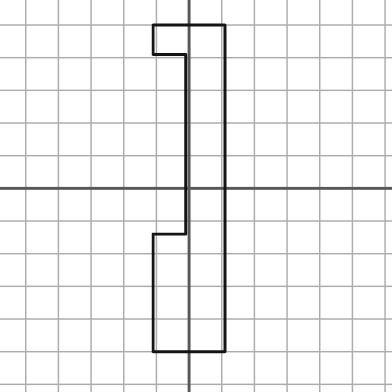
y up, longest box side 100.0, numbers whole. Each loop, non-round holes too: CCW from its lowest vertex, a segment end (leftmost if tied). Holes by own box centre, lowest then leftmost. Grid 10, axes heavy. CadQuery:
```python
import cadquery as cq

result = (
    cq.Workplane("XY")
    .moveTo(-11.0, -50.0)
    .lineTo(11.0, -50.0)
    .lineTo(11.0, 50.0)
    .lineTo(-11.0, 50.0)
    .lineTo(-11.0, 41.0)
    .lineTo(-1.0, 41.0)
    .lineTo(-1.0, -14.0)
    .lineTo(-11.0, -14.0)
    .close()
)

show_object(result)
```